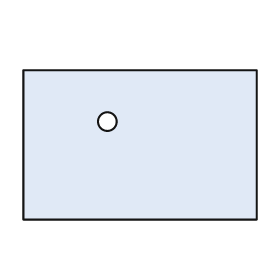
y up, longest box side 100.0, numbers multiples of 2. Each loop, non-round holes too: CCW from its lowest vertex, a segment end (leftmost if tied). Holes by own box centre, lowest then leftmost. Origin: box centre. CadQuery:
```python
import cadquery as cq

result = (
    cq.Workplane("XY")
    .moveTo(-50.0, -32.0)
    .lineTo(50.0, -32.0)
    .lineTo(50.0, 32.0)
    .lineTo(-50.0, 32.0)
    .close()
    .moveTo(-14.0, 10.0)
    .circle(4.0)
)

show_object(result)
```